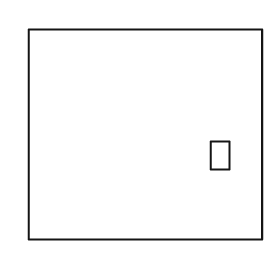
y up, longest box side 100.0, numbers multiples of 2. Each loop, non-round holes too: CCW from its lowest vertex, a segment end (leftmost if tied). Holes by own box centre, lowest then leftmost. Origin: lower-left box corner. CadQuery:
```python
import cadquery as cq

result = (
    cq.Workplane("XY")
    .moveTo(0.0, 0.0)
    .lineTo(100.0, 0.0)
    .lineTo(100.0, 90.0)
    .lineTo(0.0, 90.0)
    .close()
    .moveTo(78.0, 30.0)
    .lineTo(86.0, 30.0)
    .lineTo(86.0, 42.0)
    .lineTo(78.0, 42.0)
    .close()
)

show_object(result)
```